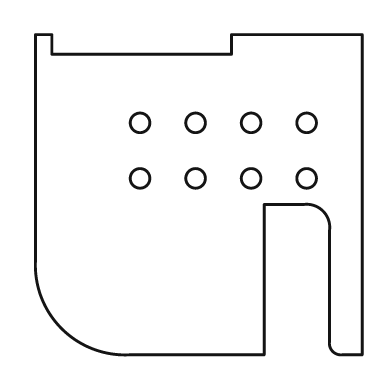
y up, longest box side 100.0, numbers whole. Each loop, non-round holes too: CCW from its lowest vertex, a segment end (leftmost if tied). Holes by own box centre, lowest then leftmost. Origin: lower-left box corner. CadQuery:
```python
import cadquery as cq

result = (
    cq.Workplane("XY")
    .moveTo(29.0, 0.0)
    .lineTo(70.0, 0.0)
    .lineTo(70.0, 46.0)
    .lineTo(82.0, 46.0)
    .threePointArc((88.0, 44.0), (90.0, 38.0))
    .lineTo(90.0, 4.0)
    .threePointArc((91.0, 1.0), (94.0, 0.0))
    .lineTo(100.0, 0.0)
    .lineTo(100.0, 98.0)
    .lineTo(60.0, 98.0)
    .lineTo(60.0, 92.0)
    .lineTo(5.0, 92.0)
    .lineTo(5.0, 98.0)
    .lineTo(0.0, 98.0)
    .lineTo(0.0, 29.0)
    .threePointArc((8.0, 8.0), (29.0, 0.0))
    .close()
    .moveTo(32.0, 54.0)
    .circle(3.0)
    .moveTo(49.0, 54.0)
    .circle(3.0)
    .moveTo(66.0, 54.0)
    .circle(3.0)
    .moveTo(83.0, 54.0)
    .circle(3.0)
    .moveTo(32.0, 71.0)
    .circle(3.0)
    .moveTo(49.0, 71.0)
    .circle(3.0)
    .moveTo(66.0, 71.0)
    .circle(3.0)
    .moveTo(83.0, 71.0)
    .circle(3.0)
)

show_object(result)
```